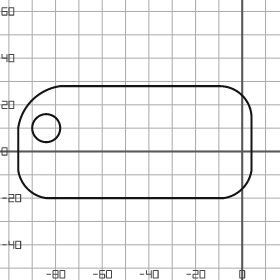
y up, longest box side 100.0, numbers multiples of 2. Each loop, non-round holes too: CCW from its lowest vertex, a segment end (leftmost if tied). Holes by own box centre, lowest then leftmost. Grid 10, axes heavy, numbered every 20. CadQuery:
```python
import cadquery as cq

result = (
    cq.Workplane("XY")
    .moveTo(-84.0, -20.0)
    .lineTo(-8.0, -20.0)
    .threePointArc((0.0, -16.0), (4.0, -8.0))
    .lineTo(4.0, 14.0)
    .threePointArc((0.0, 24.0), (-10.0, 28.0))
    .lineTo(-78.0, 28.0)
    .threePointArc((-90.0, 22.0), (-96.0, 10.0))
    .lineTo(-96.0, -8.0)
    .threePointArc((-92.0, -16.0), (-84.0, -20.0))
    .close()
    .moveTo(-84.0, 10.0)
    .circle(6.0)
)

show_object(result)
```